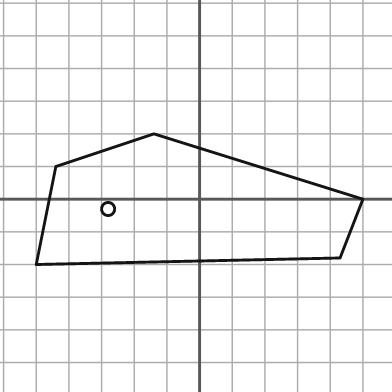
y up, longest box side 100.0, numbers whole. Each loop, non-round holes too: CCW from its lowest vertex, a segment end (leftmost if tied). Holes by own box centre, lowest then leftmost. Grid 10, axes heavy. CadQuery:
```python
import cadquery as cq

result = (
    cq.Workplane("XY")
    .moveTo(-50.0, -20.0)
    .lineTo(43.0, -18.0)
    .lineTo(50.0, 0.0)
    .lineTo(-14.0, 20.0)
    .lineTo(-44.0, 10.0)
    .close()
    .moveTo(-28.0, -3.0)
    .circle(2.0)
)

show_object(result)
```